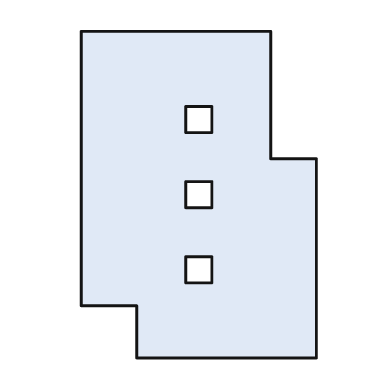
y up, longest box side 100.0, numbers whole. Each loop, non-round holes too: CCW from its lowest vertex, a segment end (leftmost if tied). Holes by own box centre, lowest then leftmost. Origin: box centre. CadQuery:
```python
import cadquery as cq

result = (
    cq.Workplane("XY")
    .moveTo(-19.0, -50.0)
    .lineTo(36.0, -50.0)
    .lineTo(36.0, 11.0)
    .lineTo(22.0, 11.0)
    .lineTo(22.0, 50.0)
    .lineTo(-36.0, 50.0)
    .lineTo(-36.0, -34.0)
    .lineTo(-19.0, -34.0)
    .close()
    .moveTo(-4.0, -27.0)
    .lineTo(4.0, -27.0)
    .lineTo(4.0, -19.0)
    .lineTo(-4.0, -19.0)
    .close()
    .moveTo(-4.0, -4.0)
    .lineTo(4.0, -4.0)
    .lineTo(4.0, 4.0)
    .lineTo(-4.0, 4.0)
    .close()
    .moveTo(-4.0, 19.0)
    .lineTo(4.0, 19.0)
    .lineTo(4.0, 27.0)
    .lineTo(-4.0, 27.0)
    .close()
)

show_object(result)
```